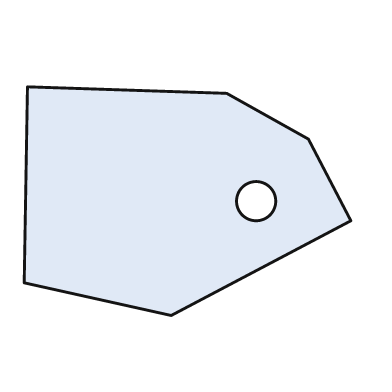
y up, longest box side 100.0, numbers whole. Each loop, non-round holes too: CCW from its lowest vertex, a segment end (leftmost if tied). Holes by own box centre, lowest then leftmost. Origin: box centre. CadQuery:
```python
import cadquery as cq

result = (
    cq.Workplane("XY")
    .moveTo(-5.0, -35.0)
    .lineTo(50.0, -6.0)
    .lineTo(37.0, 19.0)
    .lineTo(12.0, 33.0)
    .lineTo(-49.0, 35.0)
    .lineTo(-50.0, -25.0)
    .close()
    .moveTo(21.0, 0.0)
    .circle(6.0)
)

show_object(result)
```